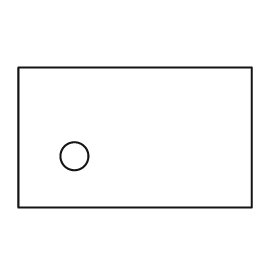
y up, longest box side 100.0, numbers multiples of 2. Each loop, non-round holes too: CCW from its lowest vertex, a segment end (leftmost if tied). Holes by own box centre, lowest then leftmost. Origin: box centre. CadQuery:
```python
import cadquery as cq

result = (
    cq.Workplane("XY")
    .moveTo(-50.0, -30.0)
    .lineTo(50.0, -30.0)
    .lineTo(50.0, 30.0)
    .lineTo(-50.0, 30.0)
    .close()
    .moveTo(-26.0, -8.0)
    .circle(6.0)
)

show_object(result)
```